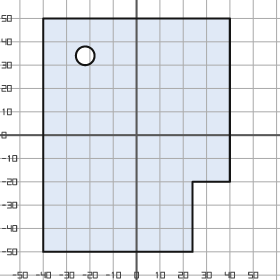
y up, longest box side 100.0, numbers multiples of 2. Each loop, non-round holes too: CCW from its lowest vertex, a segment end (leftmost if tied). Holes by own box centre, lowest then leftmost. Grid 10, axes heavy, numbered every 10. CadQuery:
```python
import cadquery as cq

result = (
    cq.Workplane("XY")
    .moveTo(-40.0, -50.0)
    .lineTo(24.0, -50.0)
    .lineTo(24.0, -20.0)
    .lineTo(40.0, -20.0)
    .lineTo(40.0, 50.0)
    .lineTo(-40.0, 50.0)
    .close()
    .moveTo(-22.0, 34.0)
    .circle(4.0)
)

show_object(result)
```